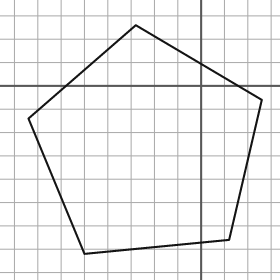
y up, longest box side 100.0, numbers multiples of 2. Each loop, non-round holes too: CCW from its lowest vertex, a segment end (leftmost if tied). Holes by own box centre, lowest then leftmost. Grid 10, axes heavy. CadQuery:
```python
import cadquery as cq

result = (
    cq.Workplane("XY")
    .moveTo(-50.0, -72.0)
    .lineTo(12.0, -66.0)
    .lineTo(26.0, -6.0)
    .lineTo(-28.0, 26.0)
    .lineTo(-74.0, -14.0)
    .close()
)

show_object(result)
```